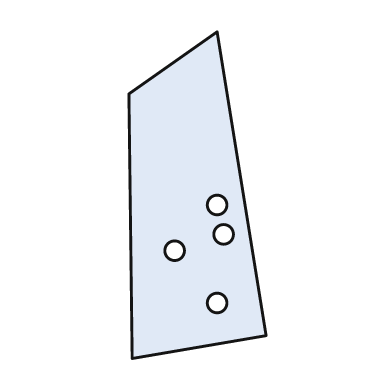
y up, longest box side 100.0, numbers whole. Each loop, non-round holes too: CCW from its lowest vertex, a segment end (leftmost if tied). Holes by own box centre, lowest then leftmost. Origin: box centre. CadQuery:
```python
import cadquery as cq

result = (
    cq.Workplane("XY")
    .moveTo(-20.0, -50.0)
    .lineTo(21.0, -43.0)
    .lineTo(6.0, 50.0)
    .lineTo(-21.0, 31.0)
    .close()
    .moveTo(6.0, -33.0)
    .circle(3.0)
    .moveTo(-7.0, -17.0)
    .circle(3.0)
    .moveTo(8.0, -12.0)
    .circle(3.0)
    .moveTo(6.0, -3.0)
    .circle(3.0)
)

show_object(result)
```